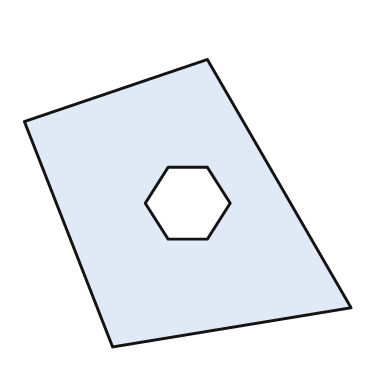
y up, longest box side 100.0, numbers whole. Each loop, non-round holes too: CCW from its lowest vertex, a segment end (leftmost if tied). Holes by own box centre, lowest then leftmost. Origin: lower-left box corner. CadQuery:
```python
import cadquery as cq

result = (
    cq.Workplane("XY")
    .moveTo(27.0, 0.0)
    .lineTo(100.0, 12.0)
    .lineTo(56.0, 88.0)
    .lineTo(0.0, 69.0)
    .close()
    .moveTo(44.0, 33.0)
    .lineTo(56.0, 33.0)
    .lineTo(63.0, 44.0)
    .lineTo(56.0, 55.0)
    .lineTo(44.0, 55.0)
    .lineTo(37.0, 44.0)
    .close()
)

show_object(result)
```